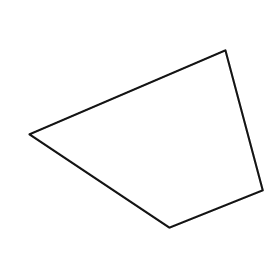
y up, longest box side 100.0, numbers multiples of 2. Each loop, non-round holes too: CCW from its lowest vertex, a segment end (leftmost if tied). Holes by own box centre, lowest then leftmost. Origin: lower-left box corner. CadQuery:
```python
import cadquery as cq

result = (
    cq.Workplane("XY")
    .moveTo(60.0, 0.0)
    .lineTo(100.0, 16.0)
    .lineTo(84.0, 76.0)
    .lineTo(0.0, 40.0)
    .close()
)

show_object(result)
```